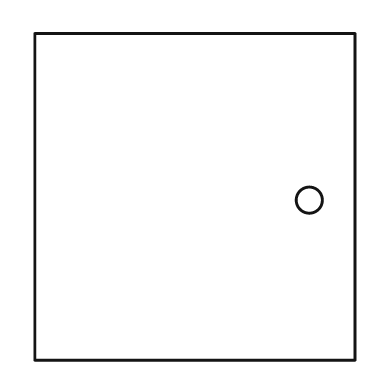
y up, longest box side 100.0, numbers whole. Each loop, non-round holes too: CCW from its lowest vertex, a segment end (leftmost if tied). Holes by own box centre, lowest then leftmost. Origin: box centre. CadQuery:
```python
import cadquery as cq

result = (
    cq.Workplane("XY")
    .moveTo(-49.0, -50.0)
    .lineTo(49.0, -50.0)
    .lineTo(49.0, 50.0)
    .lineTo(-49.0, 50.0)
    .close()
    .moveTo(35.0, -1.0)
    .circle(4.0)
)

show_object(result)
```